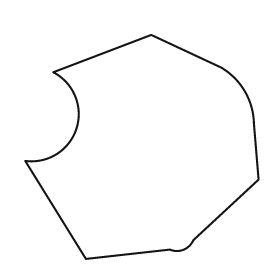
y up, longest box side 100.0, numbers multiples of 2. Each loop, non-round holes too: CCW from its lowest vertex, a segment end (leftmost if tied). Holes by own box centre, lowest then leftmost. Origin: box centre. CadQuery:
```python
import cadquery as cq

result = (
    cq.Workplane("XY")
    .moveTo(-24.0, -48.0)
    .lineTo(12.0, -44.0)
    .threePointArc((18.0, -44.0), (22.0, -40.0))
    .lineTo(50.0, -14.0)
    .lineTo(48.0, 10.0)
    .threePointArc((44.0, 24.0), (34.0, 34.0))
    .lineTo(4.0, 48.0)
    .lineTo(-38.0, 32.0)
    .threePointArc((-28.0, 8.0), (-50.0, -6.0))
    .close()
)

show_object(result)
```